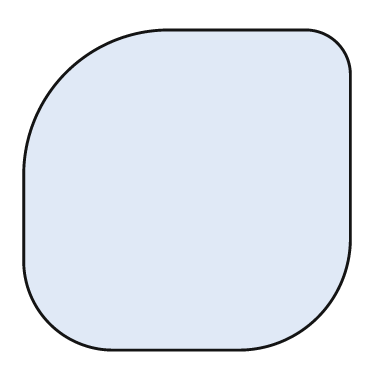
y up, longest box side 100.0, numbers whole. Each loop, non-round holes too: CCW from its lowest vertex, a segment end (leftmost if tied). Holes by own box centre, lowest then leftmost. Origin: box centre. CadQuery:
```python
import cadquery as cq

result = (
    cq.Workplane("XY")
    .moveTo(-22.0, -49.0)
    .lineTo(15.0, -49.0)
    .threePointArc((40.0, -39.0), (50.0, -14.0))
    .lineTo(50.0, 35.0)
    .threePointArc((46.0, 45.0), (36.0, 49.0))
    .lineTo(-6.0, 49.0)
    .threePointArc((-37.0, 36.0), (-50.0, 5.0))
    .lineTo(-50.0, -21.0)
    .threePointArc((-42.0, -41.0), (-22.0, -49.0))
    .close()
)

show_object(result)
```